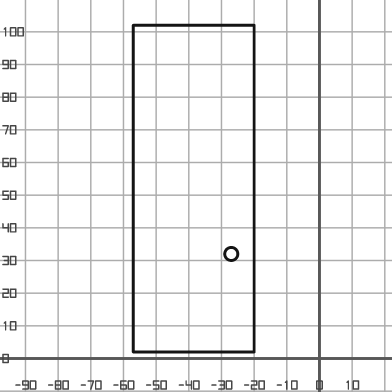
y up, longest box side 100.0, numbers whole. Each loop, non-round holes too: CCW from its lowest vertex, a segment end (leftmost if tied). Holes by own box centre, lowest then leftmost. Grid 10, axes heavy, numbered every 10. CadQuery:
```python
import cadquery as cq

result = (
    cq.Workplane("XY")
    .moveTo(-57.0, 2.0)
    .lineTo(-20.0, 2.0)
    .lineTo(-20.0, 102.0)
    .lineTo(-57.0, 102.0)
    .close()
    .moveTo(-27.0, 32.0)
    .circle(2.0)
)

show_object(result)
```